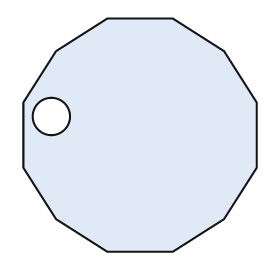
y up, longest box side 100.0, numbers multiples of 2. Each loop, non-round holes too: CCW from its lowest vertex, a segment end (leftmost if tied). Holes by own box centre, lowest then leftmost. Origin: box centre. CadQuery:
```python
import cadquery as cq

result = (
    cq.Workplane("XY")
    .moveTo(-14.0, -50.0)
    .lineTo(14.0, -50.0)
    .lineTo(36.0, -36.0)
    .lineTo(50.0, -14.0)
    .lineTo(50.0, 14.0)
    .lineTo(36.0, 36.0)
    .lineTo(14.0, 50.0)
    .lineTo(-14.0, 50.0)
    .lineTo(-36.0, 36.0)
    .lineTo(-50.0, 14.0)
    .lineTo(-50.0, -14.0)
    .lineTo(-36.0, -36.0)
    .close()
    .moveTo(-38.0, 8.0)
    .circle(8.0)
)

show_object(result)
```